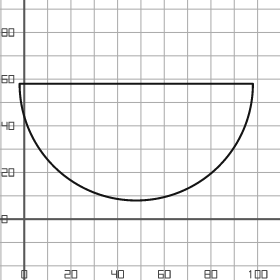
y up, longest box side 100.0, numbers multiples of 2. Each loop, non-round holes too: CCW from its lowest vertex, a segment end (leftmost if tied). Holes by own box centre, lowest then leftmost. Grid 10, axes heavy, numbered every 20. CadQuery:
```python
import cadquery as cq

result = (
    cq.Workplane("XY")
    .moveTo(-2.0, 58.0)
    .threePointArc((48.0, 8.0), (98.0, 58.0))
    .close()
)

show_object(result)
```